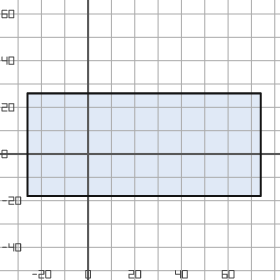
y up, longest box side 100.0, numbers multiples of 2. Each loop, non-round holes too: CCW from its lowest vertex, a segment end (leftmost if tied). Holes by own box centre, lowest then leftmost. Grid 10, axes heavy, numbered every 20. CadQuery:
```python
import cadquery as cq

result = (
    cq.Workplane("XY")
    .moveTo(-26.0, -18.0)
    .lineTo(74.0, -18.0)
    .lineTo(74.0, 26.0)
    .lineTo(-26.0, 26.0)
    .close()
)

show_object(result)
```